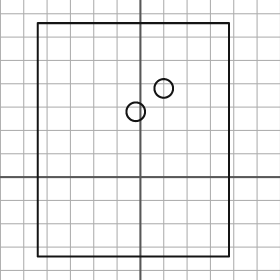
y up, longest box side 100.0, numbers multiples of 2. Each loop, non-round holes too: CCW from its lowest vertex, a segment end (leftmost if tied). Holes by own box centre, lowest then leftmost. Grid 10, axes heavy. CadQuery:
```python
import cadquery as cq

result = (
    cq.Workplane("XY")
    .moveTo(-44.0, -34.0)
    .lineTo(38.0, -34.0)
    .lineTo(38.0, 66.0)
    .lineTo(-44.0, 66.0)
    .close()
    .moveTo(-2.0, 28.0)
    .circle(4.0)
    .moveTo(10.0, 38.0)
    .circle(4.0)
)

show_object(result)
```